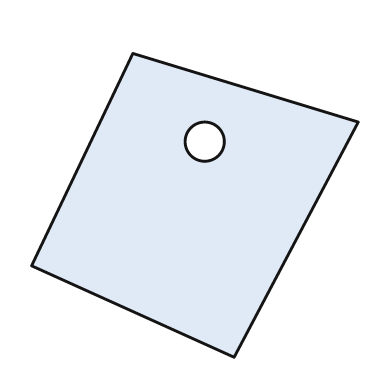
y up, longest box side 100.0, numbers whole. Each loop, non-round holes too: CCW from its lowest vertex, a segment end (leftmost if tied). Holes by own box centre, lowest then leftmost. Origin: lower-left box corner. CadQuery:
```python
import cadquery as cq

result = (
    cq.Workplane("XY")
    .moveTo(62.0, 0.0)
    .lineTo(100.0, 72.0)
    .lineTo(31.0, 93.0)
    .lineTo(0.0, 28.0)
    .close()
    .moveTo(53.0, 66.0)
    .circle(6.0)
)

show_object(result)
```